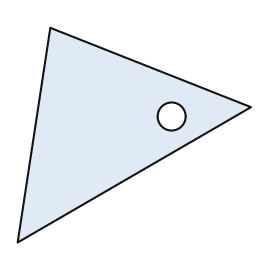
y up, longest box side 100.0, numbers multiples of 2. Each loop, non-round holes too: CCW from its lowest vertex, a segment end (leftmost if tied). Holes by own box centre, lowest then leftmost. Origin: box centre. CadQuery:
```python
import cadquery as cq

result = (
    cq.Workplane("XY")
    .moveTo(-50.0, -46.0)
    .lineTo(50.0, 12.0)
    .lineTo(-36.0, 46.0)
    .close()
    .moveTo(16.0, 8.0)
    .circle(6.0)
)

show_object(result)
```